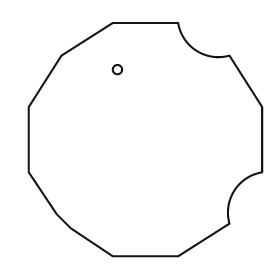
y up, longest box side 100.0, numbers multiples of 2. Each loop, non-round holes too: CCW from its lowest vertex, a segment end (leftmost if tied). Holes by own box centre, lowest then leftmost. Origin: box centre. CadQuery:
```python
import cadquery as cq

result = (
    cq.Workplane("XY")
    .moveTo(-14.0, -50.0)
    .lineTo(14.0, -50.0)
    .lineTo(36.0, -36.0)
    .threePointArc((38.0, -22.0), (50.0, -14.0))
    .lineTo(50.0, 14.0)
    .lineTo(36.0, 36.0)
    .threePointArc((22.0, 38.0), (14.0, 50.0))
    .lineTo(-14.0, 50.0)
    .lineTo(-36.0, 36.0)
    .lineTo(-50.0, 14.0)
    .lineTo(-50.0, -14.0)
    .lineTo(-38.0, -32.0)
    .lineTo(-32.0, -38.0)
    .close()
    .moveTo(-12.0, 30.0)
    .circle(2.0)
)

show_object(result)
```